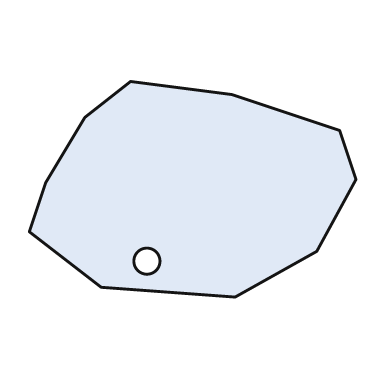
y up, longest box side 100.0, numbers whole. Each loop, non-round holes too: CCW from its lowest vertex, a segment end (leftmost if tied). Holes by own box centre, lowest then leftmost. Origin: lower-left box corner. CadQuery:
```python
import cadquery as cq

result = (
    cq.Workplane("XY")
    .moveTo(63.0, 0.0)
    .lineTo(88.0, 14.0)
    .lineTo(100.0, 36.0)
    .lineTo(95.0, 51.0)
    .lineTo(62.0, 62.0)
    .lineTo(31.0, 66.0)
    .lineTo(17.0, 55.0)
    .lineTo(5.0, 35.0)
    .lineTo(0.0, 20.0)
    .lineTo(22.0, 3.0)
    .close()
    .moveTo(36.0, 11.0)
    .circle(4.0)
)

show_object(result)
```